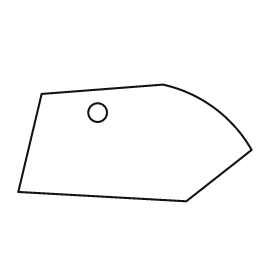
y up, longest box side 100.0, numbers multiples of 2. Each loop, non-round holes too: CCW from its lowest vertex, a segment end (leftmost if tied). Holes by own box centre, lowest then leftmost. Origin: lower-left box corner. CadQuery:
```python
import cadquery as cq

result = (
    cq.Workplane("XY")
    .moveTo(72.0, 0.0)
    .lineTo(100.0, 22.0)
    .threePointArc((84.0, 40.0), (62.0, 50.0))
    .lineTo(10.0, 46.0)
    .lineTo(0.0, 4.0)
    .close()
    .moveTo(34.0, 38.0)
    .circle(4.0)
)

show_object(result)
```